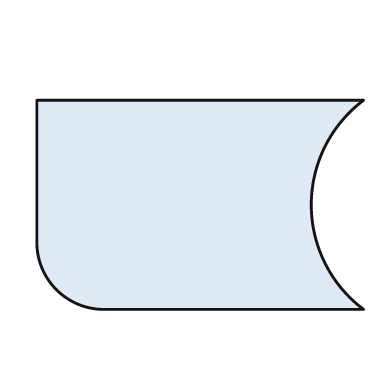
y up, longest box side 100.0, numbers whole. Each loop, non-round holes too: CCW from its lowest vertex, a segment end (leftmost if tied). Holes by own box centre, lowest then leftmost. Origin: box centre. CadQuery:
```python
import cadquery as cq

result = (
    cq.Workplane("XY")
    .moveTo(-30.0, -32.0)
    .lineTo(50.0, -32.0)
    .threePointArc((34.0, 0.0), (50.0, 32.0))
    .lineTo(-50.0, 32.0)
    .lineTo(-50.0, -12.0)
    .threePointArc((-44.0, -26.0), (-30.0, -32.0))
    .close()
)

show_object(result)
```